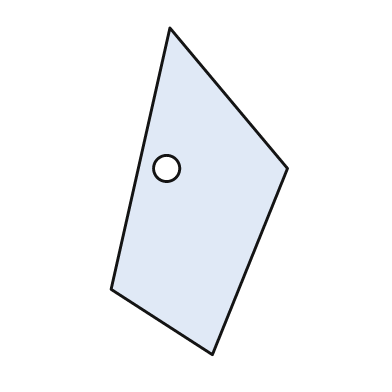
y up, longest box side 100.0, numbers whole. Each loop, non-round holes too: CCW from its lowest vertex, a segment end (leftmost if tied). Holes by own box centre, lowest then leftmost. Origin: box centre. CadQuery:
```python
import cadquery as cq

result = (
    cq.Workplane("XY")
    .moveTo(4.0, -50.0)
    .lineTo(27.0, 7.0)
    .lineTo(-9.0, 50.0)
    .lineTo(-27.0, -30.0)
    .close()
    .moveTo(-10.0, 7.0)
    .circle(4.0)
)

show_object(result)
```